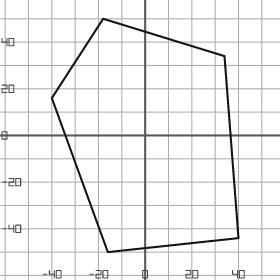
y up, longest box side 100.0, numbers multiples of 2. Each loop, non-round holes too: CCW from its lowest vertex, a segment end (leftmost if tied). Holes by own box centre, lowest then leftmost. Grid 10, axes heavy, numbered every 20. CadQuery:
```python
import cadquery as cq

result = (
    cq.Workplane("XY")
    .moveTo(-16.0, -50.0)
    .lineTo(40.0, -44.0)
    .lineTo(34.0, 34.0)
    .lineTo(-18.0, 50.0)
    .lineTo(-40.0, 16.0)
    .close()
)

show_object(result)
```